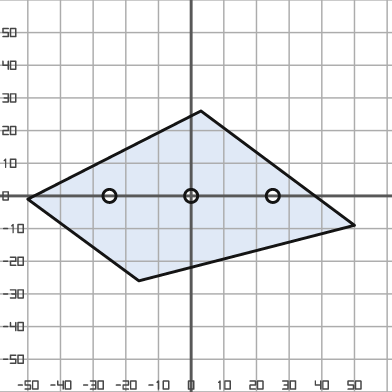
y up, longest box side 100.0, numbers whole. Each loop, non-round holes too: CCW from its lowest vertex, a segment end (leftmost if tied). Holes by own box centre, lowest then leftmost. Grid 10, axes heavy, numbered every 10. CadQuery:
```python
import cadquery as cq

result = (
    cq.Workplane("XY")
    .moveTo(-16.0, -26.0)
    .lineTo(50.0, -9.0)
    .lineTo(3.0, 26.0)
    .lineTo(-50.0, -1.0)
    .close()
    .moveTo(-25.0, 0.0)
    .circle(2.0)
    .moveTo(0.0, 0.0)
    .circle(2.0)
    .moveTo(25.0, 0.0)
    .circle(2.0)
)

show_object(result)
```